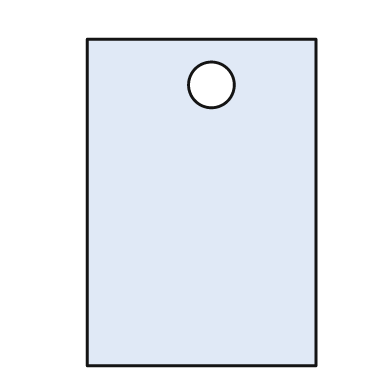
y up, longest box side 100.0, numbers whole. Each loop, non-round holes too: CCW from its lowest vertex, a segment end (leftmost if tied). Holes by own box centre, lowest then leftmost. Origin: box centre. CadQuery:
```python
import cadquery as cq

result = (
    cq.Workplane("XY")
    .moveTo(-35.0, -50.0)
    .lineTo(35.0, -50.0)
    .lineTo(35.0, 50.0)
    .lineTo(-35.0, 50.0)
    .close()
    .moveTo(3.0, 36.0)
    .circle(7.0)
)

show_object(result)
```